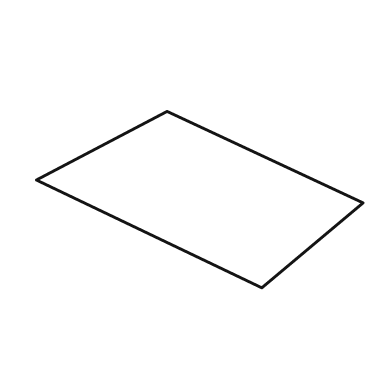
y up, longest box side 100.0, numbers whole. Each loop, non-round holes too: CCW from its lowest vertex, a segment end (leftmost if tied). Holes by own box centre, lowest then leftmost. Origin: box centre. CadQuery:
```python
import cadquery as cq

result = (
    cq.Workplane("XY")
    .moveTo(19.0, -27.0)
    .lineTo(50.0, -1.0)
    .lineTo(-10.0, 27.0)
    .lineTo(-50.0, 6.0)
    .close()
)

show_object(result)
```